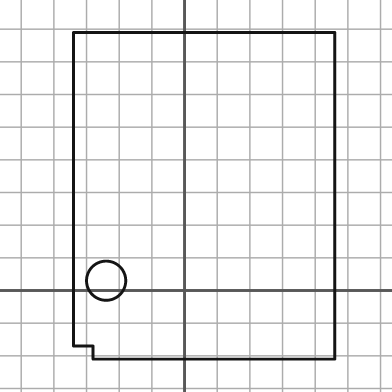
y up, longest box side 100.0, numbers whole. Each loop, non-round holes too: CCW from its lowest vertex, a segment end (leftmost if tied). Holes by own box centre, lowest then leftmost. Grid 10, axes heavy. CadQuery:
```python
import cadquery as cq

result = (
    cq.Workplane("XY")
    .moveTo(-28.0, -21.0)
    .lineTo(46.0, -21.0)
    .lineTo(46.0, 79.0)
    .lineTo(-34.0, 79.0)
    .lineTo(-34.0, -17.0)
    .lineTo(-28.0, -17.0)
    .close()
    .moveTo(-24.0, 3.0)
    .circle(6.0)
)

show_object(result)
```